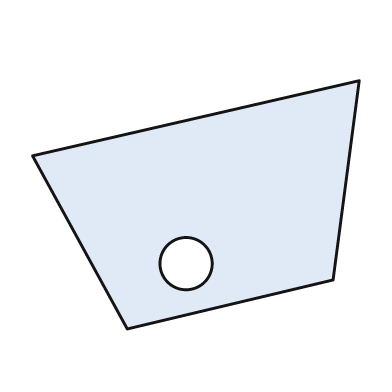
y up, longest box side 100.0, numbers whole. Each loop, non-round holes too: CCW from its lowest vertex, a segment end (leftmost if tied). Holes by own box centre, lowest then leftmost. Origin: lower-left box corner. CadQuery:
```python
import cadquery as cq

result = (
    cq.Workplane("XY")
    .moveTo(29.0, 0.0)
    .lineTo(92.0, 15.0)
    .lineTo(100.0, 76.0)
    .lineTo(0.0, 53.0)
    .close()
    .moveTo(47.0, 20.0)
    .circle(8.0)
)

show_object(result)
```